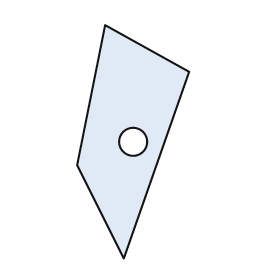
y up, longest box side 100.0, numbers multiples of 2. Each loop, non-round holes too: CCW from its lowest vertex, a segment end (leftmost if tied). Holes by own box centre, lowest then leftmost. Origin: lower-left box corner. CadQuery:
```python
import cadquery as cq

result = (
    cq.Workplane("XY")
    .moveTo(20.0, 0.0)
    .lineTo(48.0, 80.0)
    .lineTo(12.0, 100.0)
    .lineTo(0.0, 40.0)
    .close()
    .moveTo(24.0, 50.0)
    .circle(6.0)
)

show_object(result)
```